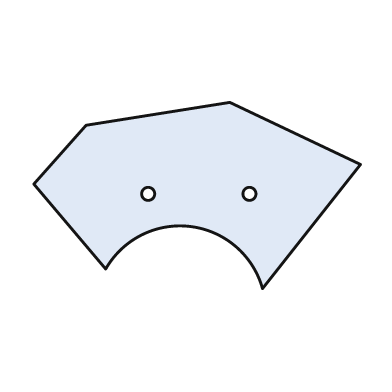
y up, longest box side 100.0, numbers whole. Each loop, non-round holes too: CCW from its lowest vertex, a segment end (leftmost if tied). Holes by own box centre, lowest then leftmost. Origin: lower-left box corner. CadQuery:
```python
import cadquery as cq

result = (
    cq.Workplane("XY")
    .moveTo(70.0, 0.0)
    .lineTo(100.0, 38.0)
    .lineTo(60.0, 57.0)
    .lineTo(16.0, 50.0)
    .lineTo(0.0, 32.0)
    .lineTo(22.0, 6.0)
    .threePointArc((48.0, 19.0), (70.0, 0.0))
    .close()
    .moveTo(35.0, 29.0)
    .circle(2.0)
    .moveTo(66.0, 29.0)
    .circle(2.0)
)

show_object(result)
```